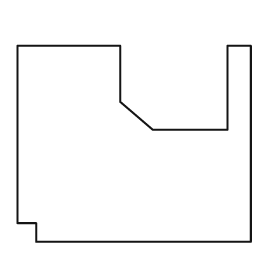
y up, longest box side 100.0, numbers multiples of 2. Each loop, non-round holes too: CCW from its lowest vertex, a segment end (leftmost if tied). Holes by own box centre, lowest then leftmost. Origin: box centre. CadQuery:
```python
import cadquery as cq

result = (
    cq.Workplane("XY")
    .moveTo(-42.0, -42.0)
    .lineTo(50.0, -42.0)
    .lineTo(50.0, 42.0)
    .lineTo(40.0, 42.0)
    .lineTo(40.0, 6.0)
    .lineTo(8.0, 6.0)
    .lineTo(-6.0, 18.0)
    .lineTo(-6.0, 42.0)
    .lineTo(-50.0, 42.0)
    .lineTo(-50.0, -34.0)
    .lineTo(-42.0, -34.0)
    .close()
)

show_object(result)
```